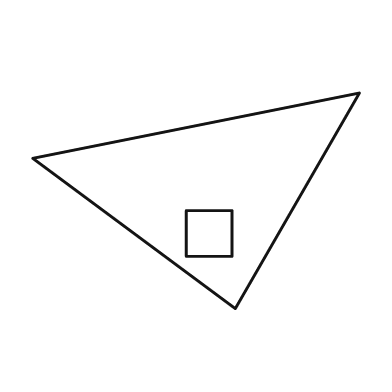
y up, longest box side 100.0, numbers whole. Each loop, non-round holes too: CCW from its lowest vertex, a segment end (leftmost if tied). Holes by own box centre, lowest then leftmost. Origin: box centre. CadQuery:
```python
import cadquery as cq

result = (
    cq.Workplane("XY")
    .moveTo(12.0, -33.0)
    .lineTo(50.0, 33.0)
    .lineTo(-50.0, 13.0)
    .close()
    .moveTo(-3.0, -17.0)
    .lineTo(11.0, -17.0)
    .lineTo(11.0, -3.0)
    .lineTo(-3.0, -3.0)
    .close()
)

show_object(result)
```